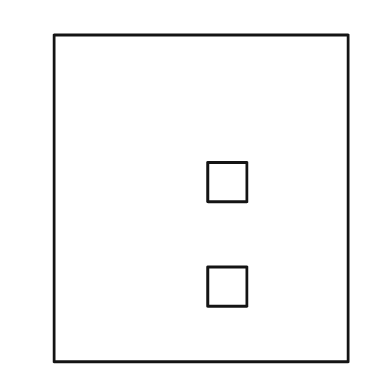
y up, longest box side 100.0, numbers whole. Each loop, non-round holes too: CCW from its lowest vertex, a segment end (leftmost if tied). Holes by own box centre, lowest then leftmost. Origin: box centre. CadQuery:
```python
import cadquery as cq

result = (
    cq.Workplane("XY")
    .moveTo(-45.0, -50.0)
    .lineTo(45.0, -50.0)
    .lineTo(45.0, 50.0)
    .lineTo(-45.0, 50.0)
    .close()
    .moveTo(2.0, -33.0)
    .lineTo(14.0, -33.0)
    .lineTo(14.0, -21.0)
    .lineTo(2.0, -21.0)
    .close()
    .moveTo(2.0, -1.0)
    .lineTo(14.0, -1.0)
    .lineTo(14.0, 11.0)
    .lineTo(2.0, 11.0)
    .close()
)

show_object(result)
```